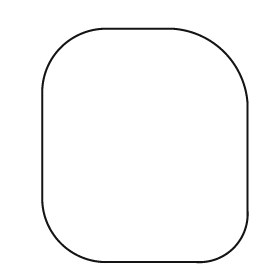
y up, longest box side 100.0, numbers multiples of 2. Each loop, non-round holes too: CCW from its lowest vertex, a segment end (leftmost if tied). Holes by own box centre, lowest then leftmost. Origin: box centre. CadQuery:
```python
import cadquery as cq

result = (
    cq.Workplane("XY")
    .moveTo(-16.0, -50.0)
    .lineTo(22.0, -50.0)
    .threePointArc((38.0, -44.0), (44.0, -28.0))
    .lineTo(44.0, 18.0)
    .threePointArc((34.0, 40.0), (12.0, 50.0))
    .lineTo(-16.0, 50.0)
    .threePointArc((-36.0, 42.0), (-44.0, 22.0))
    .lineTo(-44.0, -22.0)
    .threePointArc((-36.0, -42.0), (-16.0, -50.0))
    .close()
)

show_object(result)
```